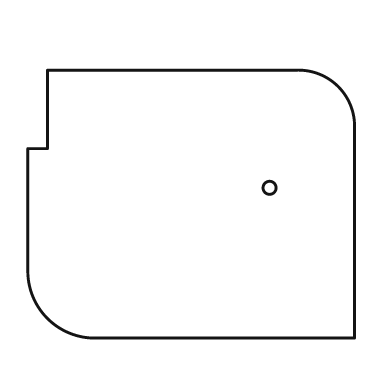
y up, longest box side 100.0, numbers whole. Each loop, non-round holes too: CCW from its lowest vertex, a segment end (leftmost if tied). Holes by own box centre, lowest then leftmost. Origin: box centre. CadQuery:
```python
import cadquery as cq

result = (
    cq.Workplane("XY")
    .moveTo(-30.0, -41.0)
    .lineTo(50.0, -41.0)
    .lineTo(50.0, 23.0)
    .threePointArc((45.0, 36.0), (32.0, 41.0))
    .lineTo(-44.0, 41.0)
    .lineTo(-44.0, 17.0)
    .lineTo(-50.0, 17.0)
    .lineTo(-50.0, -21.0)
    .threePointArc((-44.0, -35.0), (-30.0, -41.0))
    .close()
    .moveTo(24.0, 5.0)
    .circle(2.0)
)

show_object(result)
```